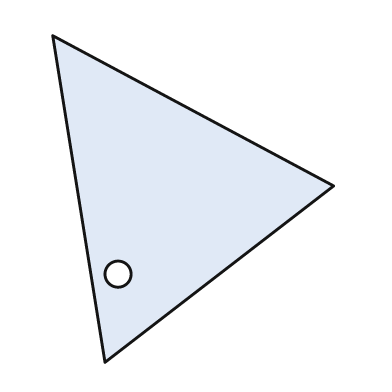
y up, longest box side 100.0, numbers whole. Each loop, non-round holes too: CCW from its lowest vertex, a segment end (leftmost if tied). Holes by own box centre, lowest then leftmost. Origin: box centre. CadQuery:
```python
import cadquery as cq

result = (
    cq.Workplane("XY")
    .moveTo(-27.0, -50.0)
    .lineTo(43.0, 4.0)
    .lineTo(-43.0, 50.0)
    .close()
    .moveTo(-23.0, -23.0)
    .circle(4.0)
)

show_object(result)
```